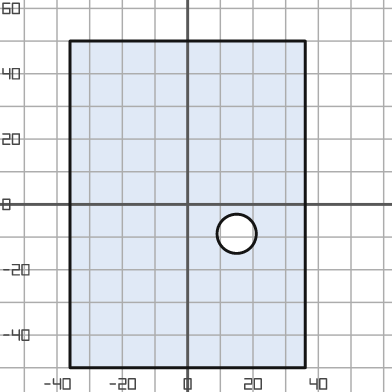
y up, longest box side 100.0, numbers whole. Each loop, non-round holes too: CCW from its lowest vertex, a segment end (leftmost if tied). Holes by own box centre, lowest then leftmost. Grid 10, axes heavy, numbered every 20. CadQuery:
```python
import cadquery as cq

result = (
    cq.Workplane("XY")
    .moveTo(-36.0, -50.0)
    .lineTo(36.0, -50.0)
    .lineTo(36.0, 50.0)
    .lineTo(-36.0, 50.0)
    .close()
    .moveTo(15.0, -9.0)
    .circle(6.0)
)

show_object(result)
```